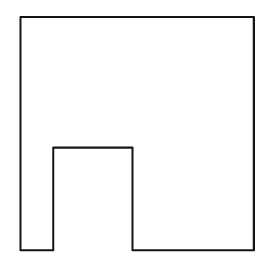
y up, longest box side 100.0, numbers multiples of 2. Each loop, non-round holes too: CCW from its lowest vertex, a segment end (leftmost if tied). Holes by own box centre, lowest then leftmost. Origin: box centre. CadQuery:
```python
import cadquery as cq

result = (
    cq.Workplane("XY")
    .moveTo(-50.0, -50.0)
    .lineTo(-36.0, -50.0)
    .lineTo(-36.0, -6.0)
    .lineTo(-2.0, -6.0)
    .lineTo(-2.0, -50.0)
    .lineTo(50.0, -50.0)
    .lineTo(50.0, 50.0)
    .lineTo(-50.0, 50.0)
    .close()
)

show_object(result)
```